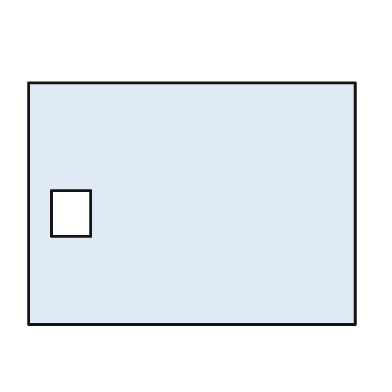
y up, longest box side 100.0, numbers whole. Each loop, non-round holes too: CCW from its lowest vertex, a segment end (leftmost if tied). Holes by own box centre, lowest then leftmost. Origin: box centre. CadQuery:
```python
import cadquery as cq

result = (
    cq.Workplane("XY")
    .moveTo(-50.0, -37.0)
    .lineTo(50.0, -37.0)
    .lineTo(50.0, 37.0)
    .lineTo(-50.0, 37.0)
    .close()
    .moveTo(-43.0, -10.0)
    .lineTo(-31.0, -10.0)
    .lineTo(-31.0, 4.0)
    .lineTo(-43.0, 4.0)
    .close()
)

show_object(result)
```